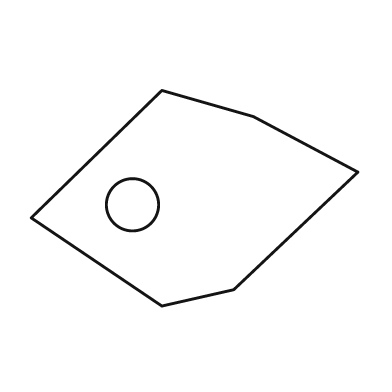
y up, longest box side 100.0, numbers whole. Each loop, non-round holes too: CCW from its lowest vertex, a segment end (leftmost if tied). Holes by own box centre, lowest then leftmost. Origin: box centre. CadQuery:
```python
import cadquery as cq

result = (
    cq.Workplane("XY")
    .moveTo(-10.0, -33.0)
    .lineTo(12.0, -28.0)
    .lineTo(50.0, 8.0)
    .lineTo(18.0, 25.0)
    .lineTo(-10.0, 33.0)
    .lineTo(-50.0, -6.0)
    .close()
    .moveTo(-19.0, -2.0)
    .circle(8.0)
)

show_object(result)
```